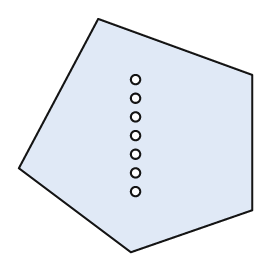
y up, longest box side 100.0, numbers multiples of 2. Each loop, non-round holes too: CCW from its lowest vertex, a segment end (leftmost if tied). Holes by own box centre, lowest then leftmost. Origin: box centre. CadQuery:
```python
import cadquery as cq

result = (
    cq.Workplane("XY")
    .moveTo(-2.0, -50.0)
    .lineTo(50.0, -32.0)
    .lineTo(50.0, 26.0)
    .lineTo(-16.0, 50.0)
    .lineTo(-50.0, -14.0)
    .close()
    .moveTo(0.0, -24.0)
    .circle(2.0)
    .moveTo(0.0, -16.0)
    .circle(2.0)
    .moveTo(0.0, -8.0)
    .circle(2.0)
    .moveTo(0.0, 0.0)
    .circle(2.0)
    .moveTo(0.0, 8.0)
    .circle(2.0)
    .moveTo(0.0, 16.0)
    .circle(2.0)
    .moveTo(0.0, 24.0)
    .circle(2.0)
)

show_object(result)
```